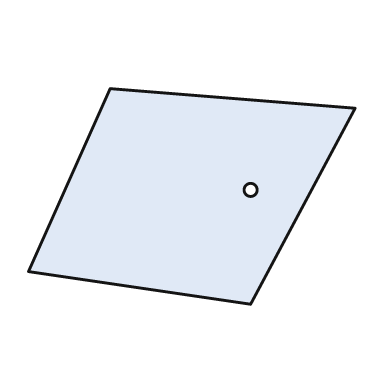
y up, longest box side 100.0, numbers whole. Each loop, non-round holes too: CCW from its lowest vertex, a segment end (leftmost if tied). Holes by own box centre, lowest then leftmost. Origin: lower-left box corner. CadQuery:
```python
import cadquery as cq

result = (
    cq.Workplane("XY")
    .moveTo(68.0, 0.0)
    .lineTo(100.0, 60.0)
    .lineTo(25.0, 66.0)
    .lineTo(0.0, 10.0)
    .close()
    .moveTo(68.0, 35.0)
    .circle(2.0)
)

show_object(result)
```